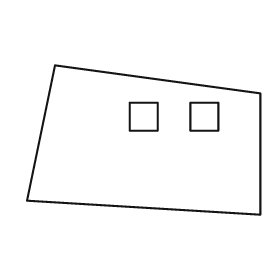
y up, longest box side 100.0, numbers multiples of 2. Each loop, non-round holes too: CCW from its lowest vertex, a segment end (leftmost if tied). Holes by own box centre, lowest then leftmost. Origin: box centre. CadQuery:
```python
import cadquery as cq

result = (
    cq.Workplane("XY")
    .moveTo(50.0, -32.0)
    .lineTo(50.0, 20.0)
    .lineTo(-38.0, 32.0)
    .lineTo(-50.0, -26.0)
    .close()
    .moveTo(-6.0, 4.0)
    .lineTo(6.0, 4.0)
    .lineTo(6.0, 16.0)
    .lineTo(-6.0, 16.0)
    .close()
    .moveTo(20.0, 4.0)
    .lineTo(32.0, 4.0)
    .lineTo(32.0, 16.0)
    .lineTo(20.0, 16.0)
    .close()
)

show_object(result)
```